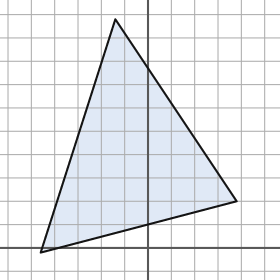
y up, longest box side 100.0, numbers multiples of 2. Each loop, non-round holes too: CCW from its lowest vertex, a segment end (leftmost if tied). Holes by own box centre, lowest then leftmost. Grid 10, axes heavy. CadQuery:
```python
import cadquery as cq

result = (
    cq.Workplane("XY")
    .moveTo(-46.0, -2.0)
    .lineTo(38.0, 20.0)
    .lineTo(-14.0, 98.0)
    .close()
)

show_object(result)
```